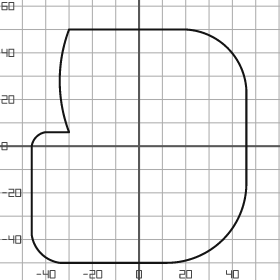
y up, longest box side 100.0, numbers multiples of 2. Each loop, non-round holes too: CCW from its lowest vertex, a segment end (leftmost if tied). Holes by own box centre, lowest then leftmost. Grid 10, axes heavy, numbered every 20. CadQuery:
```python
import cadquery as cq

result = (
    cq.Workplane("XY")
    .moveTo(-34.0, -50.0)
    .lineTo(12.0, -50.0)
    .threePointArc((36.0, -40.0), (46.0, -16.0))
    .lineTo(46.0, 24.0)
    .threePointArc((38.0, 42.0), (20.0, 50.0))
    .lineTo(-30.0, 50.0)
    .threePointArc((-34.0, 28.0), (-30.0, 6.0))
    .lineTo(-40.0, 6.0)
    .threePointArc((-44.0, 4.0), (-46.0, 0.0))
    .lineTo(-46.0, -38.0)
    .threePointArc((-42.0, -46.0), (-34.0, -50.0))
    .close()
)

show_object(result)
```